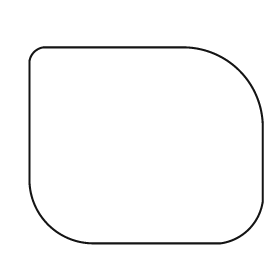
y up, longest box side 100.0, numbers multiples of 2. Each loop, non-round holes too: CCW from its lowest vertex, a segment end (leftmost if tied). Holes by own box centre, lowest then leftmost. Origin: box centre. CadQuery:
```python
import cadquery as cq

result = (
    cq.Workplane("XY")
    .moveTo(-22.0, -42.0)
    .lineTo(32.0, -42.0)
    .threePointArc((44.0, -36.0), (50.0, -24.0))
    .lineTo(50.0, 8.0)
    .threePointArc((40.0, 32.0), (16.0, 42.0))
    .lineTo(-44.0, 42.0)
    .threePointArc((-48.0, 40.0), (-50.0, 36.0))
    .lineTo(-50.0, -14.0)
    .threePointArc((-42.0, -34.0), (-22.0, -42.0))
    .close()
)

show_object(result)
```